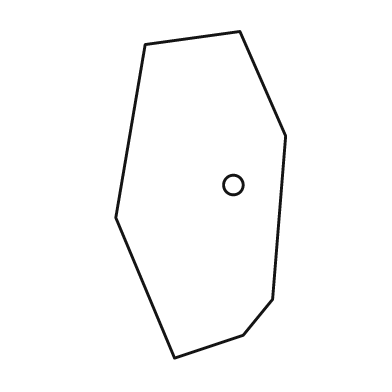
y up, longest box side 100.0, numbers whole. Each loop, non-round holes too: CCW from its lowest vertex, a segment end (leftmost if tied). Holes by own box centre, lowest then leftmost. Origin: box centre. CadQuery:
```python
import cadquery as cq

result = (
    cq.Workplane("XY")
    .moveTo(-8.0, -50.0)
    .lineTo(13.0, -43.0)
    .lineTo(22.0, -32.0)
    .lineTo(26.0, 18.0)
    .lineTo(12.0, 50.0)
    .lineTo(-17.0, 46.0)
    .lineTo(-26.0, -7.0)
    .close()
    .moveTo(10.0, 3.0)
    .circle(3.0)
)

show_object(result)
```